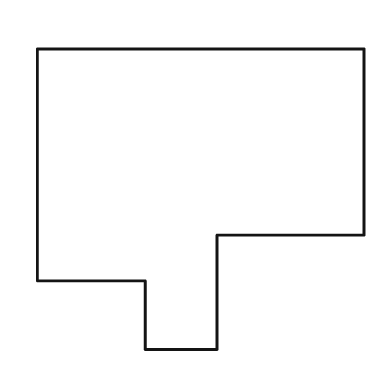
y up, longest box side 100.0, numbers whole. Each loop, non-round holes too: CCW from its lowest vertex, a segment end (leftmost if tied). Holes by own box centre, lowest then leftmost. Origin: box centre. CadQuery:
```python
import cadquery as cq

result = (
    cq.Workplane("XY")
    .moveTo(-17.0, -46.0)
    .lineTo(5.0, -46.0)
    .lineTo(5.0, -11.0)
    .lineTo(50.0, -11.0)
    .lineTo(50.0, 46.0)
    .lineTo(-50.0, 46.0)
    .lineTo(-50.0, -25.0)
    .lineTo(-17.0, -25.0)
    .close()
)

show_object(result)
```